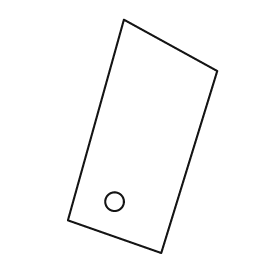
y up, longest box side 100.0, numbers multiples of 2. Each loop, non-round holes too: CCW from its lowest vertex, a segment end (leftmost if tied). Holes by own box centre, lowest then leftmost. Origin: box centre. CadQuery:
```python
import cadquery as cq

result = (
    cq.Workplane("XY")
    .moveTo(8.0, -50.0)
    .lineTo(32.0, 28.0)
    .lineTo(-8.0, 50.0)
    .lineTo(-32.0, -36.0)
    .close()
    .moveTo(-12.0, -28.0)
    .circle(4.0)
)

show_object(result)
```